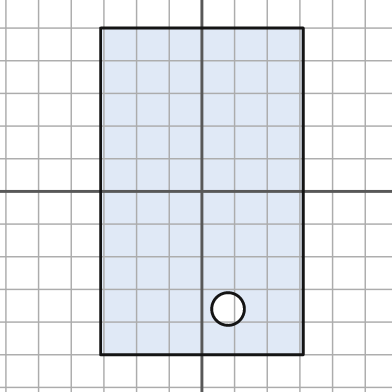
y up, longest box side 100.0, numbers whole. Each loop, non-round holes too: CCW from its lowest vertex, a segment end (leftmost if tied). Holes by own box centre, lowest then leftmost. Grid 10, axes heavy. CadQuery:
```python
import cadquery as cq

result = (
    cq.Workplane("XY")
    .moveTo(-31.0, -50.0)
    .lineTo(31.0, -50.0)
    .lineTo(31.0, 50.0)
    .lineTo(-31.0, 50.0)
    .close()
    .moveTo(8.0, -36.0)
    .circle(5.0)
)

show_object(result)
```